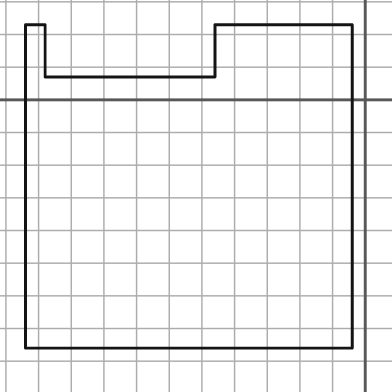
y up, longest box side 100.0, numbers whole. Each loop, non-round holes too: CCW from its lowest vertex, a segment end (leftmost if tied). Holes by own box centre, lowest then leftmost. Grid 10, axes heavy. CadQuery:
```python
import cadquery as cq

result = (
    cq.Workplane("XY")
    .moveTo(-104.0, -76.0)
    .lineTo(-4.0, -76.0)
    .lineTo(-4.0, 23.0)
    .lineTo(-46.0, 23.0)
    .lineTo(-46.0, 7.0)
    .lineTo(-98.0, 7.0)
    .lineTo(-98.0, 23.0)
    .lineTo(-104.0, 23.0)
    .close()
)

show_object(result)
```